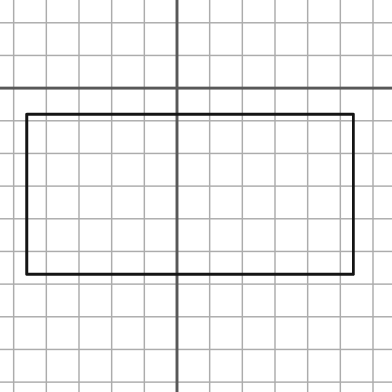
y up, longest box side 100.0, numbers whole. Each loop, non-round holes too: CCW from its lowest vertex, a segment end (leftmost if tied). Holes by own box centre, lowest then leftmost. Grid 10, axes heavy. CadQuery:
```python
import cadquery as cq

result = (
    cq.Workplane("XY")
    .moveTo(-46.0, -57.0)
    .lineTo(54.0, -57.0)
    .lineTo(54.0, -8.0)
    .lineTo(-46.0, -8.0)
    .close()
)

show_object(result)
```